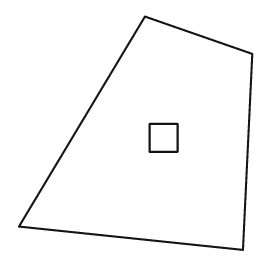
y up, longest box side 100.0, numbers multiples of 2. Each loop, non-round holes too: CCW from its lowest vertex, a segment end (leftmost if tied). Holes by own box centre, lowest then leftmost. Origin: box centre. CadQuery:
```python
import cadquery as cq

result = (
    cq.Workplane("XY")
    .moveTo(46.0, -50.0)
    .lineTo(50.0, 34.0)
    .lineTo(4.0, 50.0)
    .lineTo(-50.0, -40.0)
    .close()
    .moveTo(6.0, -8.0)
    .lineTo(18.0, -8.0)
    .lineTo(18.0, 4.0)
    .lineTo(6.0, 4.0)
    .close()
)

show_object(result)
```